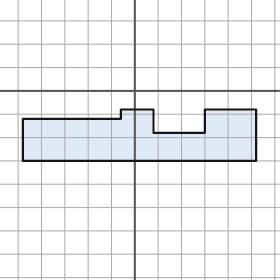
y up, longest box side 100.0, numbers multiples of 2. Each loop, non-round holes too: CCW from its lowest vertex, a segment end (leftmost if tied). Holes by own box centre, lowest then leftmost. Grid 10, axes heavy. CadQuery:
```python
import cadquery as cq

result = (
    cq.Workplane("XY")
    .moveTo(-48.0, -30.0)
    .lineTo(52.0, -30.0)
    .lineTo(52.0, -8.0)
    .lineTo(30.0, -8.0)
    .lineTo(30.0, -18.0)
    .lineTo(8.0, -18.0)
    .lineTo(8.0, -8.0)
    .lineTo(-6.0, -8.0)
    .lineTo(-6.0, -12.0)
    .lineTo(-48.0, -12.0)
    .close()
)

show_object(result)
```